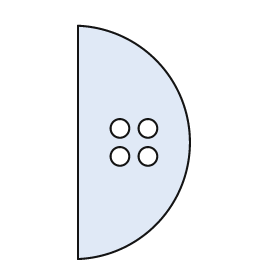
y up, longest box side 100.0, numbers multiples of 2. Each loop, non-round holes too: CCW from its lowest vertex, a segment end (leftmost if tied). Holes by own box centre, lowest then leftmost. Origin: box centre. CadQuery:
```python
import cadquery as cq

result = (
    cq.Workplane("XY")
    .moveTo(-24.0, -50.0)
    .threePointArc((24.0, 0.0), (-24.0, 50.0))
    .close()
    .moveTo(-6.0, -6.0)
    .circle(4.0)
    .moveTo(6.0, -6.0)
    .circle(4.0)
    .moveTo(-6.0, 6.0)
    .circle(4.0)
    .moveTo(6.0, 6.0)
    .circle(4.0)
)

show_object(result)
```